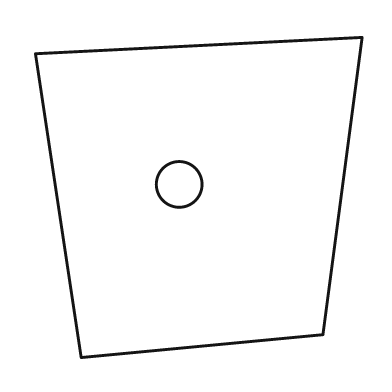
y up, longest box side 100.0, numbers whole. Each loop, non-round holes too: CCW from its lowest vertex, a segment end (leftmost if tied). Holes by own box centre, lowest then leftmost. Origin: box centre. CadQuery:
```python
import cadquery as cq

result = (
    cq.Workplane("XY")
    .moveTo(-36.0, -49.0)
    .lineTo(38.0, -42.0)
    .lineTo(50.0, 49.0)
    .lineTo(-50.0, 44.0)
    .close()
    .moveTo(-6.0, 4.0)
    .circle(7.0)
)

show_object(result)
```